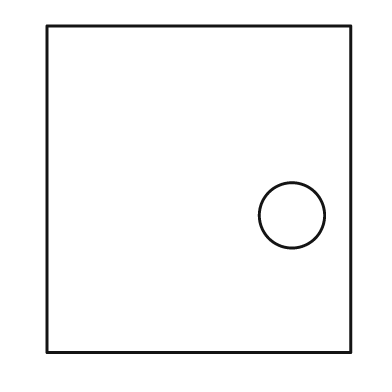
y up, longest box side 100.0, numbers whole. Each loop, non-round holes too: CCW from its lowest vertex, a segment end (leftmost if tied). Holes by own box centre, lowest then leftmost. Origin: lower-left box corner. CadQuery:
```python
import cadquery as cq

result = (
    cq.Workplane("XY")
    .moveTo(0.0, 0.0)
    .lineTo(93.0, 0.0)
    .lineTo(93.0, 100.0)
    .lineTo(0.0, 100.0)
    .close()
    .moveTo(75.0, 42.0)
    .circle(10.0)
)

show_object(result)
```